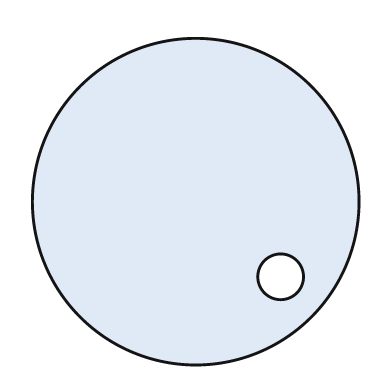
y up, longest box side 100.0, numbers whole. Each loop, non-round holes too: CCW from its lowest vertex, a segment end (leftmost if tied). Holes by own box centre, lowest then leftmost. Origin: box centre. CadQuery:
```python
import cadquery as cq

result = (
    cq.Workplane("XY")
    .moveTo(0.0, 0.0)
    .circle(50.0)
    .moveTo(26.0, -23.0)
    .circle(7.0)
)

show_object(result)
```